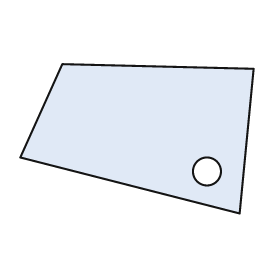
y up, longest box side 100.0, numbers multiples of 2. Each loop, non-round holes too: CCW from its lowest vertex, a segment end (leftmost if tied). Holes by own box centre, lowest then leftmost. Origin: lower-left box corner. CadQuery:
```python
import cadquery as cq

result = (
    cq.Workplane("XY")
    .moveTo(94.0, 0.0)
    .lineTo(100.0, 62.0)
    .lineTo(18.0, 64.0)
    .lineTo(0.0, 24.0)
    .close()
    .moveTo(80.0, 18.0)
    .circle(6.0)
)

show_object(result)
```